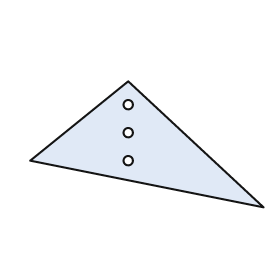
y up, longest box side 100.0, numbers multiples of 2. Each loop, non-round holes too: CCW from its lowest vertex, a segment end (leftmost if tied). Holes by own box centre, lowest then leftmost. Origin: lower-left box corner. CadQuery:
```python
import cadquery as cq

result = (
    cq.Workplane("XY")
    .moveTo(100.0, 0.0)
    .lineTo(42.0, 54.0)
    .lineTo(0.0, 20.0)
    .close()
    .moveTo(42.0, 20.0)
    .circle(2.0)
    .moveTo(42.0, 32.0)
    .circle(2.0)
    .moveTo(42.0, 44.0)
    .circle(2.0)
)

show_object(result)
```